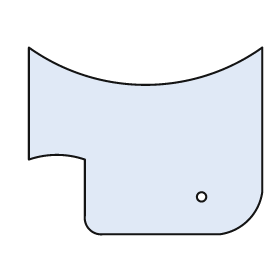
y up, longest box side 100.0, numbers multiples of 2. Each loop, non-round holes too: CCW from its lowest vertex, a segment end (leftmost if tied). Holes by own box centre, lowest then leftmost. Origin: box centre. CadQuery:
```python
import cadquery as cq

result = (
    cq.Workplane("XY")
    .moveTo(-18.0, -40.0)
    .lineTo(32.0, -40.0)
    .threePointArc((44.0, -34.0), (50.0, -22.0))
    .lineTo(50.0, 40.0)
    .threePointArc((0.0, 24.0), (-50.0, 40.0))
    .lineTo(-50.0, -8.0)
    .threePointArc((-38.0, -6.0), (-26.0, -8.0))
    .lineTo(-26.0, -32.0)
    .threePointArc((-24.0, -38.0), (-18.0, -40.0))
    .close()
    .moveTo(24.0, -24.0)
    .circle(2.0)
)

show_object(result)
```